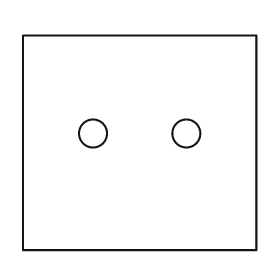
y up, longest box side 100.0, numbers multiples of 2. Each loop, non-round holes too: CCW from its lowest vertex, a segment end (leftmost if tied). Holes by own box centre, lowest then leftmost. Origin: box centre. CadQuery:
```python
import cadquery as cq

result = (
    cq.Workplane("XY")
    .moveTo(-50.0, -46.0)
    .lineTo(50.0, -46.0)
    .lineTo(50.0, 46.0)
    .lineTo(-50.0, 46.0)
    .close()
    .moveTo(-20.0, 4.0)
    .circle(6.0)
    .moveTo(20.0, 4.0)
    .circle(6.0)
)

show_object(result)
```